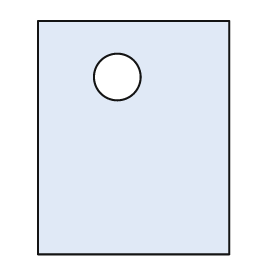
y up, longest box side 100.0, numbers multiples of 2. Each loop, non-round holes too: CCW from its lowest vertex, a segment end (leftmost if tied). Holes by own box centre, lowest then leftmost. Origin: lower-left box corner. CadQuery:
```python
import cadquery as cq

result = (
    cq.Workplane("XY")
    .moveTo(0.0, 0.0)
    .lineTo(82.0, 0.0)
    .lineTo(82.0, 100.0)
    .lineTo(0.0, 100.0)
    .close()
    .moveTo(34.0, 76.0)
    .circle(10.0)
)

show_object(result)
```